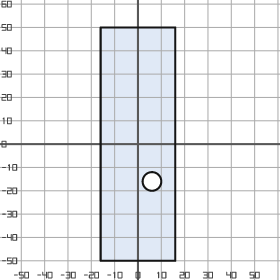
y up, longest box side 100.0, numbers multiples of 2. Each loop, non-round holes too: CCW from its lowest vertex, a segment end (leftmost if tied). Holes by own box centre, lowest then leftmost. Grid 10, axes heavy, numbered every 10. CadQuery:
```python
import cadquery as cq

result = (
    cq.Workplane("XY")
    .moveTo(-16.0, -50.0)
    .lineTo(16.0, -50.0)
    .lineTo(16.0, 50.0)
    .lineTo(-16.0, 50.0)
    .close()
    .moveTo(6.0, -16.0)
    .circle(4.0)
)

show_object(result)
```